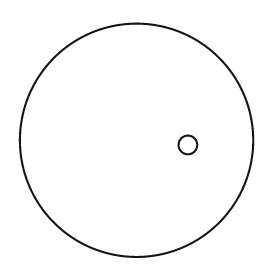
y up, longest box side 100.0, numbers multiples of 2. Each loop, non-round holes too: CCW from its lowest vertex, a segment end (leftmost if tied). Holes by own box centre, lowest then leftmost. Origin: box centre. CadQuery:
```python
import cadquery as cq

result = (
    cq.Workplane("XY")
    .moveTo(0.0, 0.0)
    .circle(50.0)
    .moveTo(22.0, -2.0)
    .circle(4.0)
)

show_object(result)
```